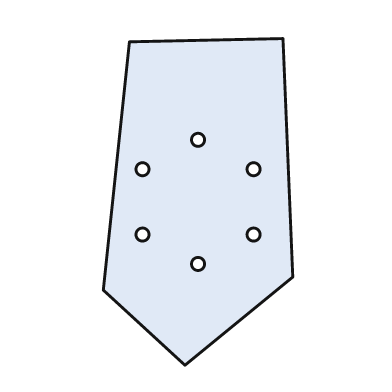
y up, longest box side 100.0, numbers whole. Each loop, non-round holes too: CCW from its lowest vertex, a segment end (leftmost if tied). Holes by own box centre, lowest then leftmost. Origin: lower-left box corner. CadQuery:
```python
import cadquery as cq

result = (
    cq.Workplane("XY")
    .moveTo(25.0, 0.0)
    .lineTo(58.0, 27.0)
    .lineTo(55.0, 100.0)
    .lineTo(8.0, 99.0)
    .lineTo(0.0, 23.0)
    .close()
    .moveTo(29.0, 31.0)
    .circle(2.0)
    .moveTo(12.0, 40.0)
    .circle(2.0)
    .moveTo(46.0, 40.0)
    .circle(2.0)
    .moveTo(12.0, 60.0)
    .circle(2.0)
    .moveTo(46.0, 60.0)
    .circle(2.0)
    .moveTo(29.0, 69.0)
    .circle(2.0)
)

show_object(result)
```